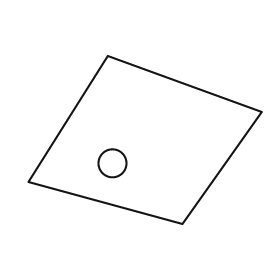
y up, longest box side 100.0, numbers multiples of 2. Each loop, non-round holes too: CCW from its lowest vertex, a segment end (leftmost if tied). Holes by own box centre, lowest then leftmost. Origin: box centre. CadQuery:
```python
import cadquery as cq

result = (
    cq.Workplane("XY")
    .moveTo(16.0, -36.0)
    .lineTo(50.0, 12.0)
    .lineTo(-16.0, 36.0)
    .lineTo(-50.0, -18.0)
    .close()
    .moveTo(-14.0, -10.0)
    .circle(6.0)
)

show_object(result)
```